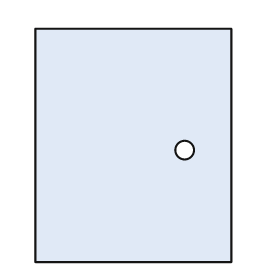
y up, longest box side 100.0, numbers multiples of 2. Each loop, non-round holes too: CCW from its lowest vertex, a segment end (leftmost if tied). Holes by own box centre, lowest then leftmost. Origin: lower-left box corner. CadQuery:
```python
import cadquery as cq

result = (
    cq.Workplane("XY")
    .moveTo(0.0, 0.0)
    .lineTo(84.0, 0.0)
    .lineTo(84.0, 100.0)
    .lineTo(0.0, 100.0)
    .close()
    .moveTo(64.0, 48.0)
    .circle(4.0)
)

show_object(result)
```